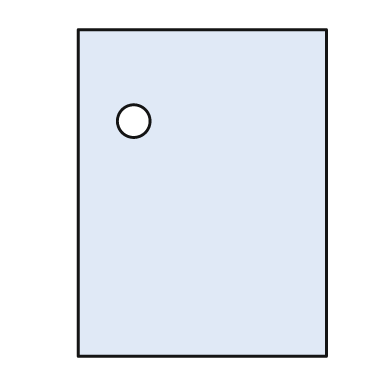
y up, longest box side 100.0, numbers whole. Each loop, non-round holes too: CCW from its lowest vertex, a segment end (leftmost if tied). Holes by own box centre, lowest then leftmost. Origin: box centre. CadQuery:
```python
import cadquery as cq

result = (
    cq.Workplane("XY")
    .moveTo(-38.0, -50.0)
    .lineTo(38.0, -50.0)
    .lineTo(38.0, 50.0)
    .lineTo(-38.0, 50.0)
    .close()
    .moveTo(-21.0, 22.0)
    .circle(5.0)
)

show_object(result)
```